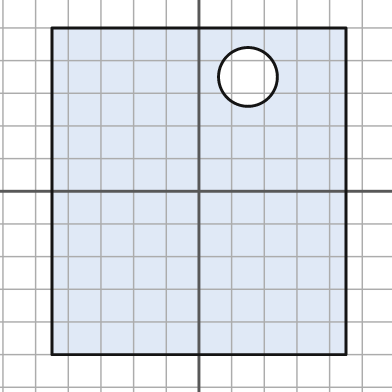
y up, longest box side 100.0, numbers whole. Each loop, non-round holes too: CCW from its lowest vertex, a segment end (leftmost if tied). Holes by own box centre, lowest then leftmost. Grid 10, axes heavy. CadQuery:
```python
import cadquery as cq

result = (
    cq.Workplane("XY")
    .moveTo(-45.0, -50.0)
    .lineTo(45.0, -50.0)
    .lineTo(45.0, 50.0)
    .lineTo(-45.0, 50.0)
    .close()
    .moveTo(15.0, 35.0)
    .circle(9.0)
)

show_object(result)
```